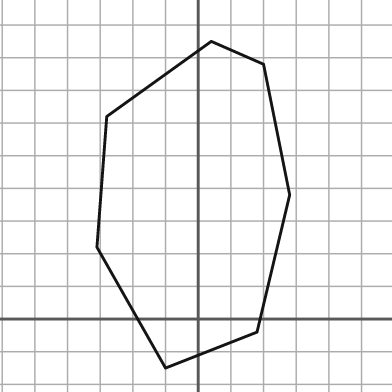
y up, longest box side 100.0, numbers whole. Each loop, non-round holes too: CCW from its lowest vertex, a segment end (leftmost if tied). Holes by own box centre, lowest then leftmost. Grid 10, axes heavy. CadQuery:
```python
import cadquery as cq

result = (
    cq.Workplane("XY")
    .moveTo(-10.0, -15.0)
    .lineTo(18.0, -4.0)
    .lineTo(28.0, 38.0)
    .lineTo(20.0, 78.0)
    .lineTo(4.0, 85.0)
    .lineTo(-28.0, 62.0)
    .lineTo(-31.0, 22.0)
    .close()
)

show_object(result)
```